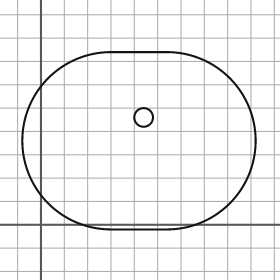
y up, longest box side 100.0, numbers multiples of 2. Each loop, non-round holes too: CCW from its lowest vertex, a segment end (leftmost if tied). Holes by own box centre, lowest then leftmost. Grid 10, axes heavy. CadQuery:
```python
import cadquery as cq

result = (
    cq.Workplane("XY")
    .moveTo(30.0, -2.0)
    .lineTo(54.0, -2.0)
    .threePointArc((92.0, 36.0), (54.0, 74.0))
    .lineTo(30.0, 74.0)
    .threePointArc((-8.0, 36.0), (30.0, -2.0))
    .close()
    .moveTo(44.0, 46.0)
    .circle(4.0)
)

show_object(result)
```